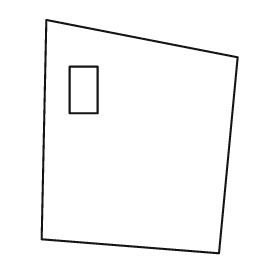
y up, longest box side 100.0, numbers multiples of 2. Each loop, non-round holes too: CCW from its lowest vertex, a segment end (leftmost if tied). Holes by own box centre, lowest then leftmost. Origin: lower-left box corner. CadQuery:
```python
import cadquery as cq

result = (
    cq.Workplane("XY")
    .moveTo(76.0, 0.0)
    .lineTo(84.0, 84.0)
    .lineTo(2.0, 100.0)
    .lineTo(0.0, 6.0)
    .close()
    .moveTo(12.0, 60.0)
    .lineTo(24.0, 60.0)
    .lineTo(24.0, 80.0)
    .lineTo(12.0, 80.0)
    .close()
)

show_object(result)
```